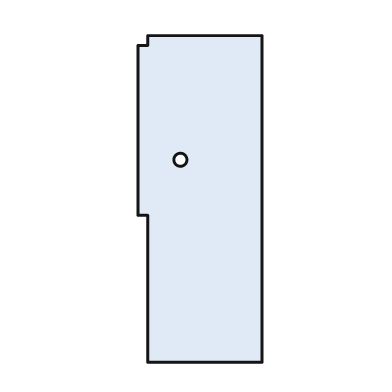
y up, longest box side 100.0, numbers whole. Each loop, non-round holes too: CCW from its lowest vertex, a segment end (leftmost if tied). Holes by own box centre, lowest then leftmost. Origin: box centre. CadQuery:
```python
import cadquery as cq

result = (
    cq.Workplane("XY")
    .moveTo(-16.0, -50.0)
    .lineTo(19.0, -50.0)
    .lineTo(19.0, 50.0)
    .lineTo(-16.0, 50.0)
    .lineTo(-16.0, 47.0)
    .lineTo(-19.0, 47.0)
    .lineTo(-19.0, -5.0)
    .lineTo(-16.0, -5.0)
    .close()
    .moveTo(-6.0, 12.0)
    .circle(2.0)
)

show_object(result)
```